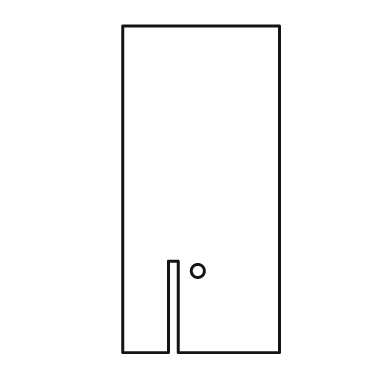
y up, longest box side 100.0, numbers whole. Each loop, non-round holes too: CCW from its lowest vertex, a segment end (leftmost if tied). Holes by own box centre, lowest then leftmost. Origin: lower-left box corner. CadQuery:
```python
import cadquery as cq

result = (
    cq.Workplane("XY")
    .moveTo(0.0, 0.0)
    .lineTo(14.0, 0.0)
    .lineTo(14.0, 28.0)
    .lineTo(17.0, 28.0)
    .lineTo(17.0, 0.0)
    .lineTo(48.0, 0.0)
    .lineTo(48.0, 100.0)
    .lineTo(0.0, 100.0)
    .close()
    .moveTo(23.0, 25.0)
    .circle(2.0)
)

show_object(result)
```